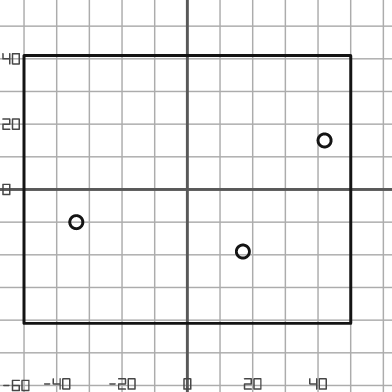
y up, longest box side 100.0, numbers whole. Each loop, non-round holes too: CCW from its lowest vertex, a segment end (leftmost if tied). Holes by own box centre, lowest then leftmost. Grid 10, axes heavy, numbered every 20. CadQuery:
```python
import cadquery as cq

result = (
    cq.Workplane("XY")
    .moveTo(-50.0, -41.0)
    .lineTo(50.0, -41.0)
    .lineTo(50.0, 41.0)
    .lineTo(-50.0, 41.0)
    .close()
    .moveTo(17.0, -19.0)
    .circle(2.0)
    .moveTo(-34.0, -10.0)
    .circle(2.0)
    .moveTo(42.0, 15.0)
    .circle(2.0)
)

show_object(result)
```